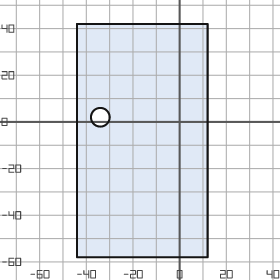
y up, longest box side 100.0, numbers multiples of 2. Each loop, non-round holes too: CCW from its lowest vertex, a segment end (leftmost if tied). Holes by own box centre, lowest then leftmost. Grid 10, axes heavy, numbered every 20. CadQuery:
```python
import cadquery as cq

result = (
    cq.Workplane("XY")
    .moveTo(-44.0, -58.0)
    .lineTo(12.0, -58.0)
    .lineTo(12.0, 42.0)
    .lineTo(-44.0, 42.0)
    .close()
    .moveTo(-34.0, 2.0)
    .circle(4.0)
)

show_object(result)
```